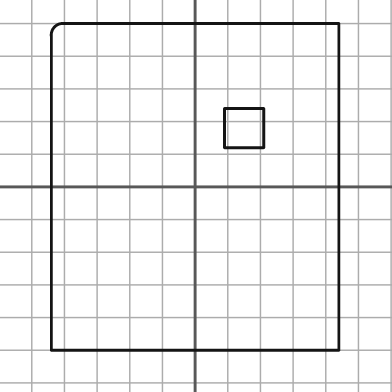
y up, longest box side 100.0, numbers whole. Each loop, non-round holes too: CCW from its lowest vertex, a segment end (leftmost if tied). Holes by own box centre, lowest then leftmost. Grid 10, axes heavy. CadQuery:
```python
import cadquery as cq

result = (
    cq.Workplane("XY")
    .moveTo(-44.0, -50.0)
    .lineTo(44.0, -50.0)
    .lineTo(44.0, 50.0)
    .lineTo(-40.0, 50.0)
    .threePointArc((-43.0, 49.0), (-44.0, 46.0))
    .close()
    .moveTo(9.0, 12.0)
    .lineTo(21.0, 12.0)
    .lineTo(21.0, 24.0)
    .lineTo(9.0, 24.0)
    .close()
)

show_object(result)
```